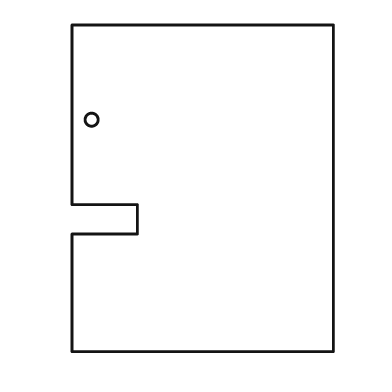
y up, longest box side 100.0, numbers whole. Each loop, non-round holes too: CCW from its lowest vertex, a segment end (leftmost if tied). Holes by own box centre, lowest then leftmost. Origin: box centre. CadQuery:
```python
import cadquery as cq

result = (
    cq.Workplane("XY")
    .moveTo(-40.0, -50.0)
    .lineTo(40.0, -50.0)
    .lineTo(40.0, 50.0)
    .lineTo(-40.0, 50.0)
    .lineTo(-40.0, -5.0)
    .lineTo(-20.0, -5.0)
    .lineTo(-20.0, -14.0)
    .lineTo(-40.0, -14.0)
    .close()
    .moveTo(-34.0, 21.0)
    .circle(2.0)
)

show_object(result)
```